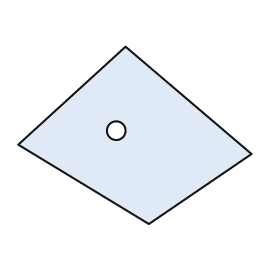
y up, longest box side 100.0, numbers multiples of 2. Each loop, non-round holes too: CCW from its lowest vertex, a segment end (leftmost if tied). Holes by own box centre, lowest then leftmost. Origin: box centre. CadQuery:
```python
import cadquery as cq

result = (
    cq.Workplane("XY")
    .moveTo(6.0, -38.0)
    .lineTo(50.0, -8.0)
    .lineTo(-4.0, 38.0)
    .lineTo(-50.0, -4.0)
    .close()
    .moveTo(-8.0, 2.0)
    .circle(4.0)
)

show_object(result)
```